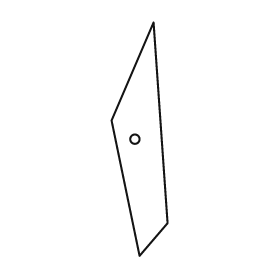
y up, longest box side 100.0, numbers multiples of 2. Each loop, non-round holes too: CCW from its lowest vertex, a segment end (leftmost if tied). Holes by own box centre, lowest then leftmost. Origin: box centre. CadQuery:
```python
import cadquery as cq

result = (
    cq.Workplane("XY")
    .moveTo(0.0, -50.0)
    .lineTo(12.0, -36.0)
    .lineTo(6.0, 50.0)
    .lineTo(-12.0, 8.0)
    .close()
    .moveTo(-2.0, 0.0)
    .circle(2.0)
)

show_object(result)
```